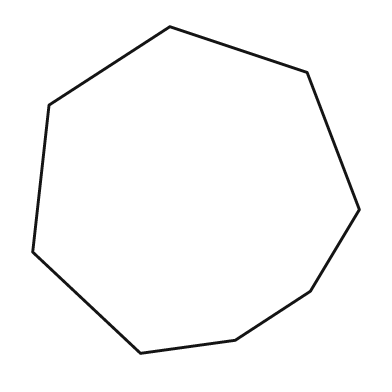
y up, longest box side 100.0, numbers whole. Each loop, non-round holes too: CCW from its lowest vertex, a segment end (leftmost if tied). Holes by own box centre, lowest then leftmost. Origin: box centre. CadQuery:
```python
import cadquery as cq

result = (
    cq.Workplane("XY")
    .moveTo(-17.0, -50.0)
    .lineTo(12.0, -46.0)
    .lineTo(35.0, -31.0)
    .lineTo(50.0, -6.0)
    .lineTo(34.0, 36.0)
    .lineTo(-8.0, 50.0)
    .lineTo(-45.0, 26.0)
    .lineTo(-50.0, -19.0)
    .close()
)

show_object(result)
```